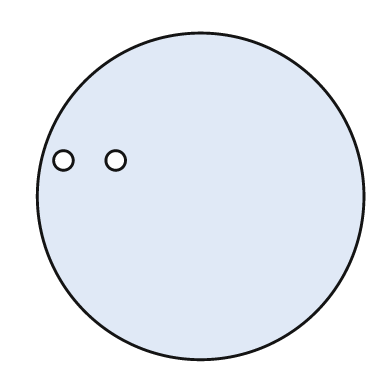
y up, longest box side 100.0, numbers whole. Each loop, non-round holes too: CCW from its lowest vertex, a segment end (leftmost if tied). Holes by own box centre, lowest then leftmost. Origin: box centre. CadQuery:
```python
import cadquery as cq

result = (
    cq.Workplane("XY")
    .moveTo(0.0, 0.0)
    .circle(50.0)
    .moveTo(-42.0, 11.0)
    .circle(3.0)
    .moveTo(-26.0, 11.0)
    .circle(3.0)
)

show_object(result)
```